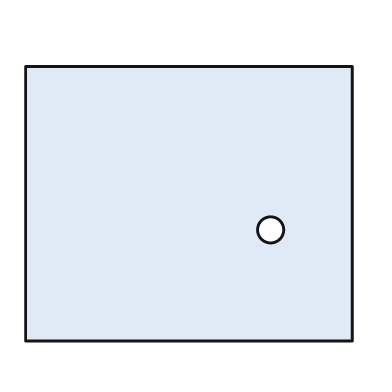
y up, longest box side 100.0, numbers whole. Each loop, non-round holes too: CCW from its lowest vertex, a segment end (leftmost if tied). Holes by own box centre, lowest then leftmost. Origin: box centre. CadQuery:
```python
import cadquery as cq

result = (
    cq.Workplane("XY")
    .moveTo(-50.0, -42.0)
    .lineTo(50.0, -42.0)
    .lineTo(50.0, 42.0)
    .lineTo(-50.0, 42.0)
    .close()
    .moveTo(25.0, -8.0)
    .circle(4.0)
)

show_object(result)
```